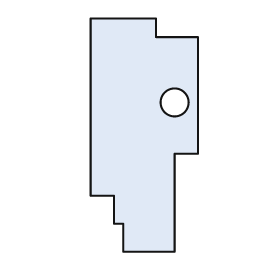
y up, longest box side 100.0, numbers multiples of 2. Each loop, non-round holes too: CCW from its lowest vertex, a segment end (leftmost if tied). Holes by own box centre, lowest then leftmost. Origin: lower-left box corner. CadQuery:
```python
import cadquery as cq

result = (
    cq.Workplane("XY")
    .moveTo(14.0, 0.0)
    .lineTo(36.0, 0.0)
    .lineTo(36.0, 42.0)
    .lineTo(46.0, 42.0)
    .lineTo(46.0, 92.0)
    .lineTo(28.0, 92.0)
    .lineTo(28.0, 100.0)
    .lineTo(0.0, 100.0)
    .lineTo(0.0, 24.0)
    .lineTo(10.0, 24.0)
    .lineTo(10.0, 12.0)
    .lineTo(14.0, 12.0)
    .close()
    .moveTo(36.0, 64.0)
    .circle(6.0)
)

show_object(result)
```